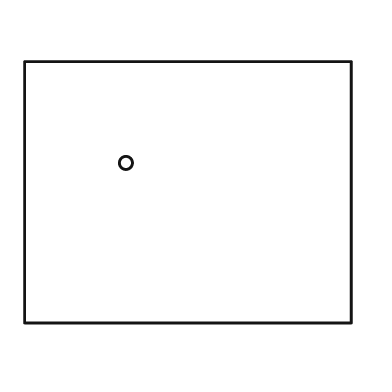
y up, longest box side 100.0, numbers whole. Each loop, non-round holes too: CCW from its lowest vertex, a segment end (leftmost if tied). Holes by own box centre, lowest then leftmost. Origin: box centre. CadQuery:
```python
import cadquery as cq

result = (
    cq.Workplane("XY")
    .moveTo(-50.0, -40.0)
    .lineTo(50.0, -40.0)
    .lineTo(50.0, 40.0)
    .lineTo(-50.0, 40.0)
    .close()
    .moveTo(-19.0, 9.0)
    .circle(2.0)
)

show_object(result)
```